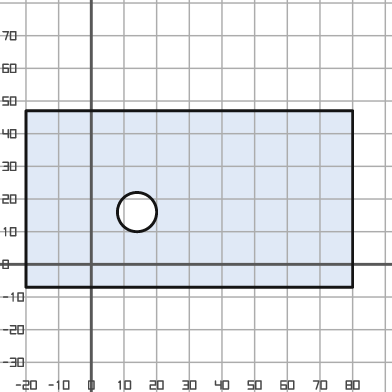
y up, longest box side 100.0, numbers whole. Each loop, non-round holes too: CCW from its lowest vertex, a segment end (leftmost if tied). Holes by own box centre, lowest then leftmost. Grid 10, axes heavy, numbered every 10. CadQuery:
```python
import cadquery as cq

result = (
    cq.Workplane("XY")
    .moveTo(-20.0, -7.0)
    .lineTo(80.0, -7.0)
    .lineTo(80.0, 47.0)
    .lineTo(-20.0, 47.0)
    .close()
    .moveTo(14.0, 16.0)
    .circle(6.0)
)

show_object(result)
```